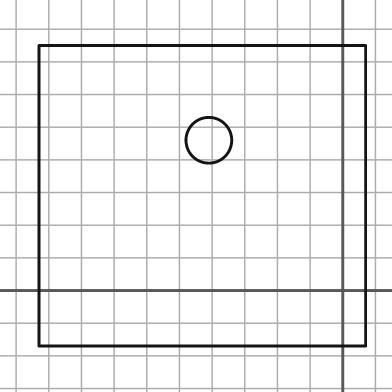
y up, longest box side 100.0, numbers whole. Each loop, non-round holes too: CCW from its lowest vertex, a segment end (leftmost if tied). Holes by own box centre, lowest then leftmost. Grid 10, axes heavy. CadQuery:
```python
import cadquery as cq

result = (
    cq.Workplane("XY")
    .moveTo(-93.0, -17.0)
    .lineTo(7.0, -17.0)
    .lineTo(7.0, 75.0)
    .lineTo(-93.0, 75.0)
    .close()
    .moveTo(-41.0, 46.0)
    .circle(7.0)
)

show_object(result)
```